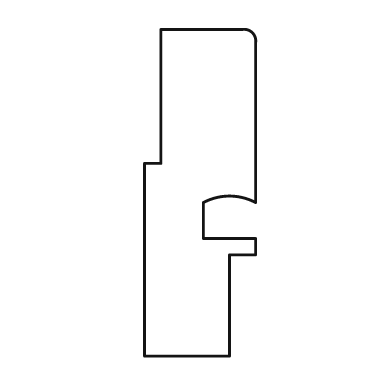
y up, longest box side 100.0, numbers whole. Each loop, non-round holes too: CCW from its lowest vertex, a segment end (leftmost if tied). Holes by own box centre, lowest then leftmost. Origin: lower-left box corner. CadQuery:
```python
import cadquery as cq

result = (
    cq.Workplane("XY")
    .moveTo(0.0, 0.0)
    .lineTo(26.0, 0.0)
    .lineTo(26.0, 31.0)
    .lineTo(34.0, 31.0)
    .lineTo(34.0, 36.0)
    .lineTo(18.0, 36.0)
    .lineTo(18.0, 47.0)
    .threePointArc((26.0, 49.0), (34.0, 47.0))
    .lineTo(34.0, 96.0)
    .threePointArc((33.0, 99.0), (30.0, 100.0))
    .lineTo(5.0, 100.0)
    .lineTo(5.0, 59.0)
    .lineTo(0.0, 59.0)
    .close()
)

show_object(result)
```